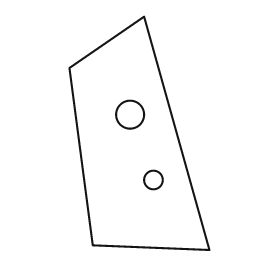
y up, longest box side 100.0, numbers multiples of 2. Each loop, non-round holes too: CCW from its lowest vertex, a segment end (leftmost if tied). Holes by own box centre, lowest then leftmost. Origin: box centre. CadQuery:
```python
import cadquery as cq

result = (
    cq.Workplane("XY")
    .moveTo(30.0, -50.0)
    .lineTo(2.0, 50.0)
    .lineTo(-30.0, 28.0)
    .lineTo(-20.0, -48.0)
    .close()
    .moveTo(6.0, -20.0)
    .circle(4.0)
    .moveTo(-4.0, 8.0)
    .circle(6.0)
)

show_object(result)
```